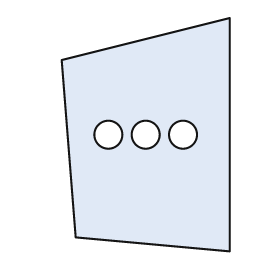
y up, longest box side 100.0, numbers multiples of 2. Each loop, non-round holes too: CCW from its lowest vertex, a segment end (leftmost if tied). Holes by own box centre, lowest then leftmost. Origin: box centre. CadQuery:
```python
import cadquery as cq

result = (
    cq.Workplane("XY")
    .moveTo(36.0, -50.0)
    .lineTo(36.0, 50.0)
    .lineTo(-36.0, 32.0)
    .lineTo(-30.0, -44.0)
    .close()
    .moveTo(-16.0, 0.0)
    .circle(6.0)
    .moveTo(0.0, 0.0)
    .circle(6.0)
    .moveTo(16.0, 0.0)
    .circle(6.0)
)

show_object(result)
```